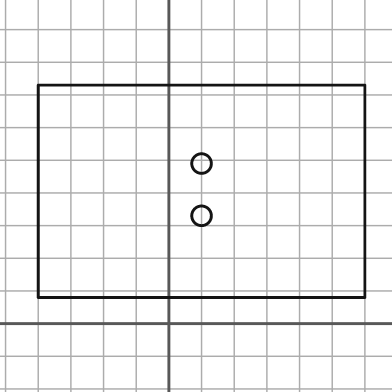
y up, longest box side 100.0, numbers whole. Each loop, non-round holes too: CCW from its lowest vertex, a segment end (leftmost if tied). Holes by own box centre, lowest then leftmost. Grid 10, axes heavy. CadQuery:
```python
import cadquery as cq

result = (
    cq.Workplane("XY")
    .moveTo(-40.0, 8.0)
    .lineTo(60.0, 8.0)
    .lineTo(60.0, 73.0)
    .lineTo(-40.0, 73.0)
    .close()
    .moveTo(10.0, 33.0)
    .circle(3.0)
    .moveTo(10.0, 49.0)
    .circle(3.0)
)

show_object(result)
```